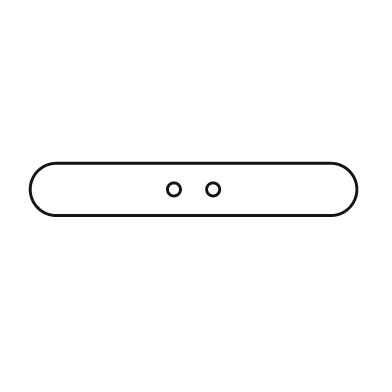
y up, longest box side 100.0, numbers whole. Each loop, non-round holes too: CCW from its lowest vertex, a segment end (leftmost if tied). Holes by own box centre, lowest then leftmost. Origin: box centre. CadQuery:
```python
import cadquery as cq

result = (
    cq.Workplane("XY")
    .moveTo(-42.0, -8.0)
    .lineTo(42.0, -8.0)
    .threePointArc((50.0, 0.0), (42.0, 8.0))
    .lineTo(-42.0, 8.0)
    .threePointArc((-50.0, 0.0), (-42.0, -8.0))
    .close()
    .moveTo(-6.0, 0.0)
    .circle(2.0)
    .moveTo(6.0, 0.0)
    .circle(2.0)
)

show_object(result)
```